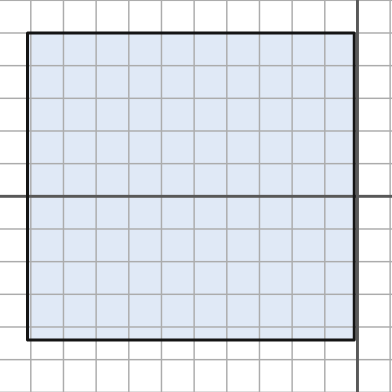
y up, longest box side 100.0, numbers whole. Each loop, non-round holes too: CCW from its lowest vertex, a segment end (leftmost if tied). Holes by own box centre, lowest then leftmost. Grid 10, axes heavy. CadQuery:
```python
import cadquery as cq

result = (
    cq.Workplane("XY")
    .moveTo(-101.0, -44.0)
    .lineTo(-1.0, -44.0)
    .lineTo(-1.0, 50.0)
    .lineTo(-101.0, 50.0)
    .close()
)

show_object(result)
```